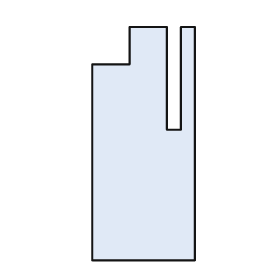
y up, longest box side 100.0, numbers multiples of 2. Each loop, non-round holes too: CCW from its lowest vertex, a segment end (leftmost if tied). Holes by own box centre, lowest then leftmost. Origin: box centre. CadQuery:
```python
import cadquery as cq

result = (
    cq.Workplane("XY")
    .moveTo(-22.0, -50.0)
    .lineTo(22.0, -50.0)
    .lineTo(22.0, 50.0)
    .lineTo(16.0, 50.0)
    .lineTo(16.0, 6.0)
    .lineTo(10.0, 6.0)
    .lineTo(10.0, 50.0)
    .lineTo(-6.0, 50.0)
    .lineTo(-6.0, 34.0)
    .lineTo(-22.0, 34.0)
    .close()
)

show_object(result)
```